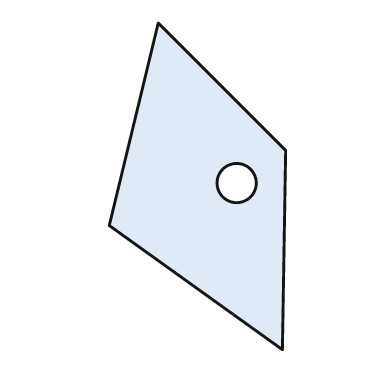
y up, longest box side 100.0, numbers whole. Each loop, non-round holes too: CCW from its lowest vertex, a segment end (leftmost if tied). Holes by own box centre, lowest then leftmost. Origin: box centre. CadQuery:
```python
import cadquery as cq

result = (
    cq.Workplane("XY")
    .moveTo(26.0, -50.0)
    .lineTo(27.0, 11.0)
    .lineTo(-12.0, 50.0)
    .lineTo(-27.0, -12.0)
    .close()
    .moveTo(12.0, 1.0)
    .circle(6.0)
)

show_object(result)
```